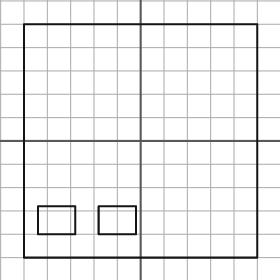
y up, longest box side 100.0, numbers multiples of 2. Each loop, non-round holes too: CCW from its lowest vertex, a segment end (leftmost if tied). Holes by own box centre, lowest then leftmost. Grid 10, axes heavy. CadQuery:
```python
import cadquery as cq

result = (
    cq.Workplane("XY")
    .moveTo(-50.0, -50.0)
    .lineTo(50.0, -50.0)
    .lineTo(50.0, 50.0)
    .lineTo(-50.0, 50.0)
    .close()
    .moveTo(-44.0, -40.0)
    .lineTo(-28.0, -40.0)
    .lineTo(-28.0, -28.0)
    .lineTo(-44.0, -28.0)
    .close()
    .moveTo(-18.0, -40.0)
    .lineTo(-2.0, -40.0)
    .lineTo(-2.0, -28.0)
    .lineTo(-18.0, -28.0)
    .close()
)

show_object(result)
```